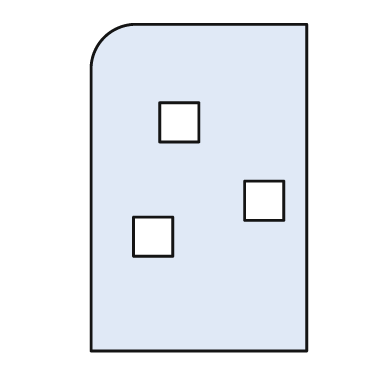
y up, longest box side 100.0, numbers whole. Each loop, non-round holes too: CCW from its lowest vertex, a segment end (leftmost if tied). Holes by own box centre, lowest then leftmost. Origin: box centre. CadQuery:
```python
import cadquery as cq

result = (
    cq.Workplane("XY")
    .moveTo(-33.0, -50.0)
    .lineTo(33.0, -50.0)
    .lineTo(33.0, 50.0)
    .lineTo(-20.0, 50.0)
    .threePointArc((-29.0, 46.0), (-33.0, 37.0))
    .close()
    .moveTo(-20.0, -21.0)
    .lineTo(-8.0, -21.0)
    .lineTo(-8.0, -9.0)
    .lineTo(-20.0, -9.0)
    .close()
    .moveTo(14.0, -10.0)
    .lineTo(26.0, -10.0)
    .lineTo(26.0, 2.0)
    .lineTo(14.0, 2.0)
    .close()
    .moveTo(-12.0, 14.0)
    .lineTo(0.0, 14.0)
    .lineTo(0.0, 26.0)
    .lineTo(-12.0, 26.0)
    .close()
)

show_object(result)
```